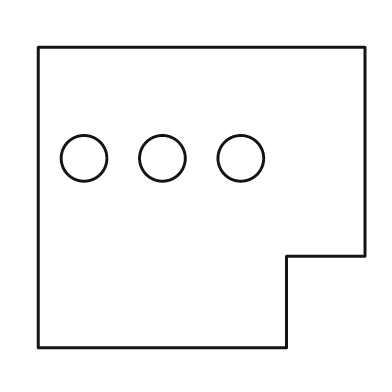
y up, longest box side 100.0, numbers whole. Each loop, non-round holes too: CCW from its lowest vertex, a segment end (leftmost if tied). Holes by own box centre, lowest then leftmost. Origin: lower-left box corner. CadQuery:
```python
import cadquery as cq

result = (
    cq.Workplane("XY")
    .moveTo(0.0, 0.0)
    .lineTo(76.0, 0.0)
    .lineTo(76.0, 28.0)
    .lineTo(100.0, 28.0)
    .lineTo(100.0, 92.0)
    .lineTo(0.0, 92.0)
    .close()
    .moveTo(14.0, 58.0)
    .circle(7.0)
    .moveTo(38.0, 58.0)
    .circle(7.0)
    .moveTo(62.0, 58.0)
    .circle(7.0)
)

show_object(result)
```